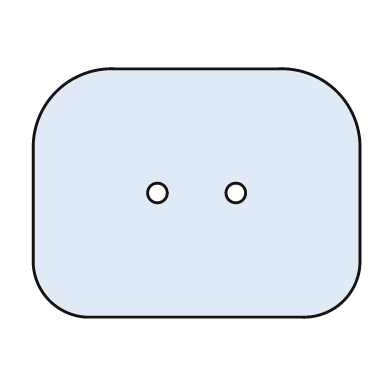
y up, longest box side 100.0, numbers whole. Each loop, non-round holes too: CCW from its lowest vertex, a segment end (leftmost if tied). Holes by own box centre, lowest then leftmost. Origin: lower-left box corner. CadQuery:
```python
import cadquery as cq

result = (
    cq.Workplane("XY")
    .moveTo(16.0, 0.0)
    .lineTo(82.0, 0.0)
    .threePointArc((95.0, 5.0), (100.0, 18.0))
    .lineTo(100.0, 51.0)
    .threePointArc((93.0, 69.0), (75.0, 76.0))
    .lineTo(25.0, 76.0)
    .threePointArc((7.0, 69.0), (0.0, 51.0))
    .lineTo(0.0, 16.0)
    .threePointArc((5.0, 5.0), (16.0, 0.0))
    .close()
    .moveTo(38.0, 38.0)
    .circle(3.0)
    .moveTo(62.0, 38.0)
    .circle(3.0)
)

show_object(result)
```